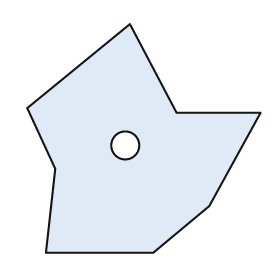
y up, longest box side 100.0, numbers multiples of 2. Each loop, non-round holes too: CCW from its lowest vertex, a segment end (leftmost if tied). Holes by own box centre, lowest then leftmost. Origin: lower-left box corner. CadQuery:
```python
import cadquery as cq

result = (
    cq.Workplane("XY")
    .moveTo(8.0, 0.0)
    .lineTo(54.0, 0.0)
    .lineTo(78.0, 20.0)
    .lineTo(100.0, 60.0)
    .lineTo(64.0, 60.0)
    .lineTo(44.0, 98.0)
    .lineTo(0.0, 62.0)
    .lineTo(12.0, 36.0)
    .close()
    .moveTo(42.0, 46.0)
    .circle(6.0)
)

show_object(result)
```